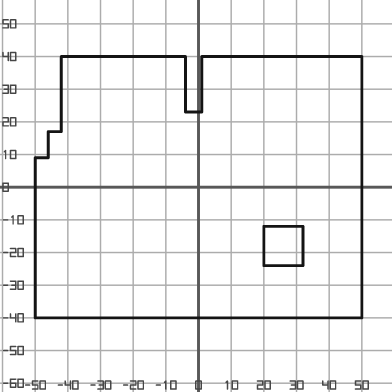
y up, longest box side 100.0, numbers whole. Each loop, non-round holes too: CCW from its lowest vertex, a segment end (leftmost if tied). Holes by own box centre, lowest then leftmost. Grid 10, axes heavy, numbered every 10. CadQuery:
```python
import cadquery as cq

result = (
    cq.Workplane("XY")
    .moveTo(-50.0, -40.0)
    .lineTo(50.0, -40.0)
    .lineTo(50.0, 40.0)
    .lineTo(1.0, 40.0)
    .lineTo(1.0, 23.0)
    .lineTo(-4.0, 23.0)
    .lineTo(-4.0, 40.0)
    .lineTo(-42.0, 40.0)
    .lineTo(-42.0, 17.0)
    .lineTo(-46.0, 17.0)
    .lineTo(-46.0, 9.0)
    .lineTo(-50.0, 9.0)
    .close()
    .moveTo(20.0, -24.0)
    .lineTo(32.0, -24.0)
    .lineTo(32.0, -12.0)
    .lineTo(20.0, -12.0)
    .close()
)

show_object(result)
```